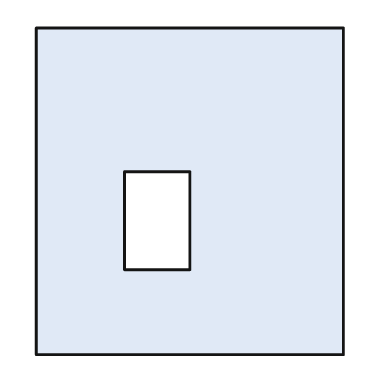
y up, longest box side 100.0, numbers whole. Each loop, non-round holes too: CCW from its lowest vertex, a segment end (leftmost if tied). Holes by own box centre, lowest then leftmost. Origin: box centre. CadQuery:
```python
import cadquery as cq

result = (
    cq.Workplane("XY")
    .moveTo(-47.0, -50.0)
    .lineTo(47.0, -50.0)
    .lineTo(47.0, 50.0)
    .lineTo(-47.0, 50.0)
    .close()
    .moveTo(-20.0, -24.0)
    .lineTo(0.0, -24.0)
    .lineTo(0.0, 6.0)
    .lineTo(-20.0, 6.0)
    .close()
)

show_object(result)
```